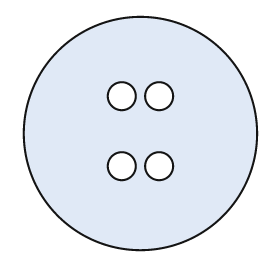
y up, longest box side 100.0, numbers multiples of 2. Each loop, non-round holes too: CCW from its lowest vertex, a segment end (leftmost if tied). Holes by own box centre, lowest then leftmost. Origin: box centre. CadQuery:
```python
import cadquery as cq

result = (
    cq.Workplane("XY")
    .moveTo(0.0, 0.0)
    .circle(50.0)
    .moveTo(-8.0, -14.0)
    .circle(6.0)
    .moveTo(8.0, -14.0)
    .circle(6.0)
    .moveTo(-8.0, 16.0)
    .circle(6.0)
    .moveTo(8.0, 16.0)
    .circle(6.0)
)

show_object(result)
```